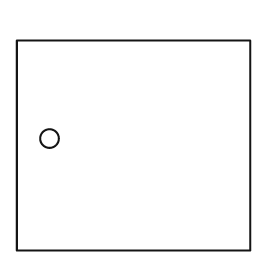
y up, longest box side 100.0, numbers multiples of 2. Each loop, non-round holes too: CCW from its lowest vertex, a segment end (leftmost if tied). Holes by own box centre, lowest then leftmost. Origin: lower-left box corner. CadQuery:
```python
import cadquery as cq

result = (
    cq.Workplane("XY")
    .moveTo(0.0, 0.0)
    .lineTo(100.0, 0.0)
    .lineTo(100.0, 90.0)
    .lineTo(0.0, 90.0)
    .close()
    .moveTo(14.0, 48.0)
    .circle(4.0)
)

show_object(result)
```